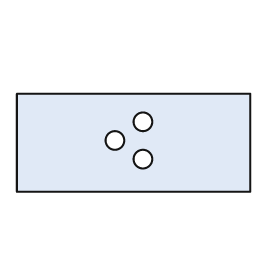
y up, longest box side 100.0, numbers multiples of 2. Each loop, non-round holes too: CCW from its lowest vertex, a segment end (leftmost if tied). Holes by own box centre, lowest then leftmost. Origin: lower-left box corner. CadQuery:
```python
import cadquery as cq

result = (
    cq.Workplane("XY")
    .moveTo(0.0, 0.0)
    .lineTo(100.0, 0.0)
    .lineTo(100.0, 42.0)
    .lineTo(0.0, 42.0)
    .close()
    .moveTo(54.0, 14.0)
    .circle(4.0)
    .moveTo(42.0, 22.0)
    .circle(4.0)
    .moveTo(54.0, 30.0)
    .circle(4.0)
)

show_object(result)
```